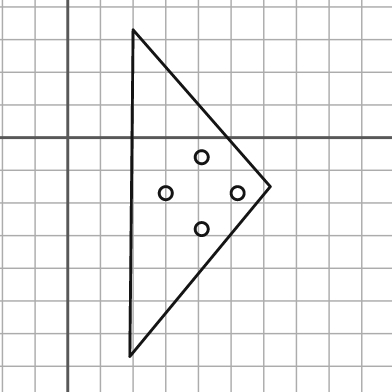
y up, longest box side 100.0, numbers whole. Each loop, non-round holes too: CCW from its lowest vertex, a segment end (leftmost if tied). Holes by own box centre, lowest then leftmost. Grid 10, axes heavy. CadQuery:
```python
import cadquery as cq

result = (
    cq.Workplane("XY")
    .moveTo(19.0, -67.0)
    .lineTo(62.0, -15.0)
    .lineTo(20.0, 33.0)
    .close()
    .moveTo(41.0, -28.0)
    .circle(2.0)
    .moveTo(30.0, -17.0)
    .circle(2.0)
    .moveTo(52.0, -17.0)
    .circle(2.0)
    .moveTo(41.0, -6.0)
    .circle(2.0)
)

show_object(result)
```